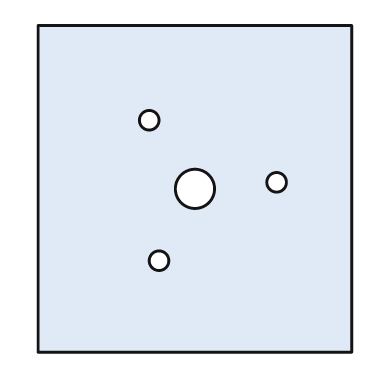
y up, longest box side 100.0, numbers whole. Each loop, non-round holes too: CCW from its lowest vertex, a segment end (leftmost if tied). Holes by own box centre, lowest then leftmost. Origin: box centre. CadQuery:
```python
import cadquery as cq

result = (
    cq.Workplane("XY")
    .moveTo(-48.0, -50.0)
    .lineTo(48.0, -50.0)
    .lineTo(48.0, 50.0)
    .lineTo(-48.0, 50.0)
    .close()
    .moveTo(-11.0, -22.0)
    .circle(3.0)
    .moveTo(0.0, 0.0)
    .circle(6.0)
    .moveTo(25.0, 2.0)
    .circle(3.0)
    .moveTo(-14.0, 21.0)
    .circle(3.0)
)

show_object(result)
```